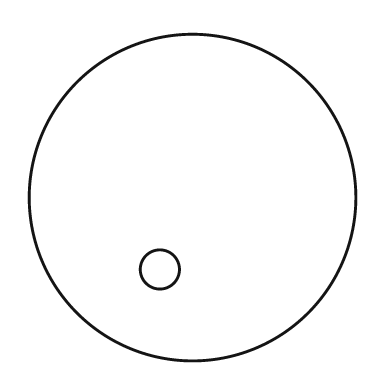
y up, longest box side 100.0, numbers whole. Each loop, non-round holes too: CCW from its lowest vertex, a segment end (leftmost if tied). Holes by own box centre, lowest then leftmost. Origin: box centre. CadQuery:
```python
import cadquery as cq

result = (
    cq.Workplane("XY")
    .moveTo(0.0, 0.0)
    .circle(50.0)
    .moveTo(-10.0, -22.0)
    .circle(6.0)
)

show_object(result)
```